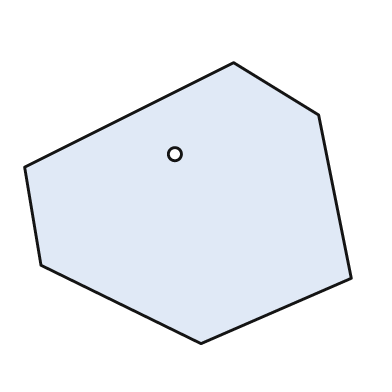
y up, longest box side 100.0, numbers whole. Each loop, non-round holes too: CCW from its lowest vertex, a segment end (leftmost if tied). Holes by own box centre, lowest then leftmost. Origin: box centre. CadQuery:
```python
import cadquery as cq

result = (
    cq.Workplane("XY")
    .moveTo(4.0, -43.0)
    .lineTo(50.0, -23.0)
    .lineTo(40.0, 27.0)
    .lineTo(14.0, 43.0)
    .lineTo(-50.0, 11.0)
    .lineTo(-45.0, -19.0)
    .close()
    .moveTo(-4.0, 15.0)
    .circle(2.0)
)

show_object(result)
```